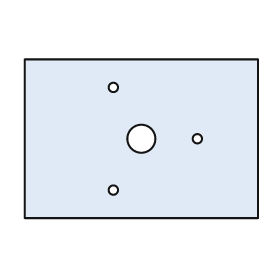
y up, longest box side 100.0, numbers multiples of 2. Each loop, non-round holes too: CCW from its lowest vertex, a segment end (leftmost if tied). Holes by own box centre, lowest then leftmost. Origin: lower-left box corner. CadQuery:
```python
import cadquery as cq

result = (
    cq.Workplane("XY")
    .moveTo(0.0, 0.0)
    .lineTo(100.0, 0.0)
    .lineTo(100.0, 68.0)
    .lineTo(0.0, 68.0)
    .close()
    .moveTo(38.0, 12.0)
    .circle(2.0)
    .moveTo(50.0, 34.0)
    .circle(6.0)
    .moveTo(74.0, 34.0)
    .circle(2.0)
    .moveTo(38.0, 56.0)
    .circle(2.0)
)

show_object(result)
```